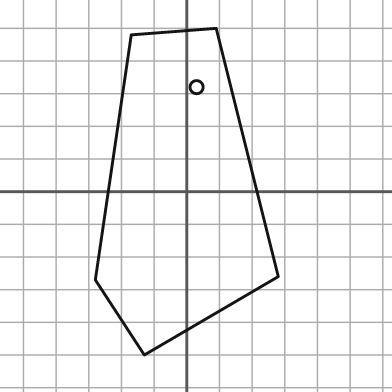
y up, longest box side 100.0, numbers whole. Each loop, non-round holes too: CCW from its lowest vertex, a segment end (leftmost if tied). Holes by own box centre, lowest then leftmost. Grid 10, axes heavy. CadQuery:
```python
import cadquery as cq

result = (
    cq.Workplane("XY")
    .moveTo(-13.0, -50.0)
    .lineTo(28.0, -26.0)
    .lineTo(9.0, 50.0)
    .lineTo(-17.0, 48.0)
    .lineTo(-28.0, -27.0)
    .close()
    .moveTo(3.0, 32.0)
    .circle(2.0)
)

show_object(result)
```